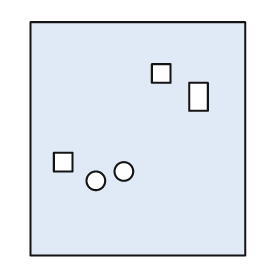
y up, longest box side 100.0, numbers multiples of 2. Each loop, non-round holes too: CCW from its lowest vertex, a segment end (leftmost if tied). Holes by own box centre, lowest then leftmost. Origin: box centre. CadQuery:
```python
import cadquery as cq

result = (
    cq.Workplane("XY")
    .moveTo(-46.0, -50.0)
    .lineTo(46.0, -50.0)
    .lineTo(46.0, 50.0)
    .lineTo(-46.0, 50.0)
    .close()
    .moveTo(-18.0, -18.0)
    .circle(4.0)
    .moveTo(-6.0, -14.0)
    .circle(4.0)
    .moveTo(-36.0, -14.0)
    .lineTo(-28.0, -14.0)
    .lineTo(-28.0, -6.0)
    .lineTo(-36.0, -6.0)
    .close()
    .moveTo(22.0, 12.0)
    .lineTo(30.0, 12.0)
    .lineTo(30.0, 24.0)
    .lineTo(22.0, 24.0)
    .close()
    .moveTo(6.0, 24.0)
    .lineTo(14.0, 24.0)
    .lineTo(14.0, 32.0)
    .lineTo(6.0, 32.0)
    .close()
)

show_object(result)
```